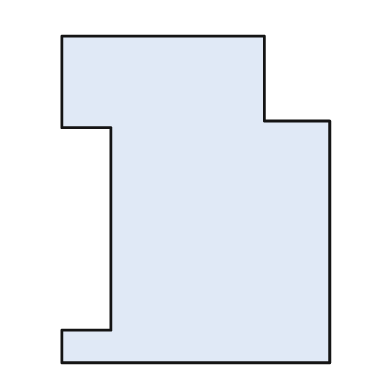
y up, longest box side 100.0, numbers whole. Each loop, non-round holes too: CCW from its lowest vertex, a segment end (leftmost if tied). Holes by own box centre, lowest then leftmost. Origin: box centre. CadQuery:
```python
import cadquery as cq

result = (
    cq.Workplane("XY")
    .moveTo(-41.0, -50.0)
    .lineTo(41.0, -50.0)
    .lineTo(41.0, 24.0)
    .lineTo(21.0, 24.0)
    .lineTo(21.0, 50.0)
    .lineTo(-41.0, 50.0)
    .lineTo(-41.0, 22.0)
    .lineTo(-26.0, 22.0)
    .lineTo(-26.0, -40.0)
    .lineTo(-41.0, -40.0)
    .close()
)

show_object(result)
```